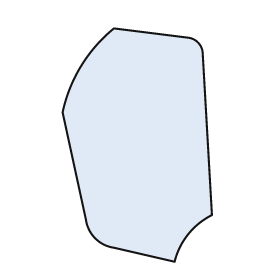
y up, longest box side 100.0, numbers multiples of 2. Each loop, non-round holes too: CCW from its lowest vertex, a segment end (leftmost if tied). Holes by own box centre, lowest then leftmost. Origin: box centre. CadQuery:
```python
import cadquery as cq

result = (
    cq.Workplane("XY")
    .moveTo(16.0, -50.0)
    .threePointArc((22.0, -38.0), (32.0, -30.0))
    .lineTo(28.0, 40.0)
    .threePointArc((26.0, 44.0), (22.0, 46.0))
    .lineTo(-10.0, 50.0)
    .threePointArc((-24.0, 34.0), (-32.0, 14.0))
    .lineTo(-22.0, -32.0)
    .threePointArc((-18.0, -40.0), (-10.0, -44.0))
    .close()
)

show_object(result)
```